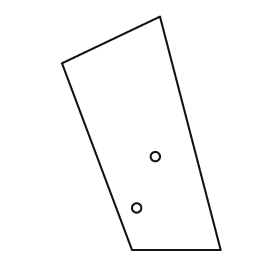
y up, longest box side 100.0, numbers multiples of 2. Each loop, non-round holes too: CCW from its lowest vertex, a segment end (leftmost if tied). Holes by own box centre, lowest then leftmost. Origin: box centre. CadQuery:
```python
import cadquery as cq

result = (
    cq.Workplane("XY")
    .moveTo(-4.0, -50.0)
    .lineTo(34.0, -50.0)
    .lineTo(8.0, 50.0)
    .lineTo(-34.0, 30.0)
    .close()
    .moveTo(-2.0, -32.0)
    .circle(2.0)
    .moveTo(6.0, -10.0)
    .circle(2.0)
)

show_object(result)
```